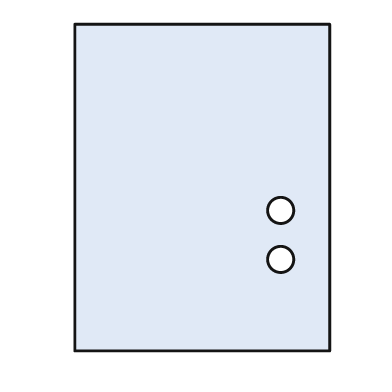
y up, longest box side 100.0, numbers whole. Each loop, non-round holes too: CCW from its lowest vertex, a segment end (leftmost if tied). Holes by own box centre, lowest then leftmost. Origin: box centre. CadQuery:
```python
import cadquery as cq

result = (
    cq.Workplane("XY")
    .moveTo(-39.0, -50.0)
    .lineTo(39.0, -50.0)
    .lineTo(39.0, 50.0)
    .lineTo(-39.0, 50.0)
    .close()
    .moveTo(24.0, -22.0)
    .circle(4.0)
    .moveTo(24.0, -7.0)
    .circle(4.0)
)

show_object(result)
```